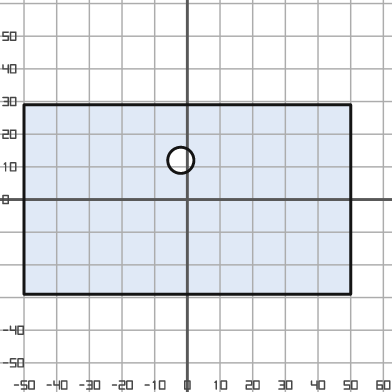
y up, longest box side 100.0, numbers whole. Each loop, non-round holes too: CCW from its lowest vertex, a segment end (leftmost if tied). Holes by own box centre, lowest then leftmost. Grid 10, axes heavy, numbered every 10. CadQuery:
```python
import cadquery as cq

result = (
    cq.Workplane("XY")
    .moveTo(-50.0, -29.0)
    .lineTo(50.0, -29.0)
    .lineTo(50.0, 29.0)
    .lineTo(-50.0, 29.0)
    .close()
    .moveTo(-2.0, 12.0)
    .circle(4.0)
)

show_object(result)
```